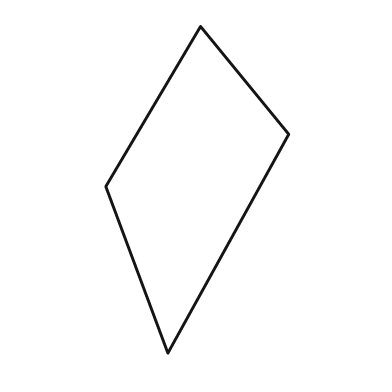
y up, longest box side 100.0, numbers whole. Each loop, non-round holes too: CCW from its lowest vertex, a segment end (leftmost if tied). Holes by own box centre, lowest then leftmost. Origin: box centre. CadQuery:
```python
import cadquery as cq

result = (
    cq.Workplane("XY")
    .moveTo(-9.0, -50.0)
    .lineTo(28.0, 17.0)
    .lineTo(1.0, 50.0)
    .lineTo(-28.0, 1.0)
    .close()
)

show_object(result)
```